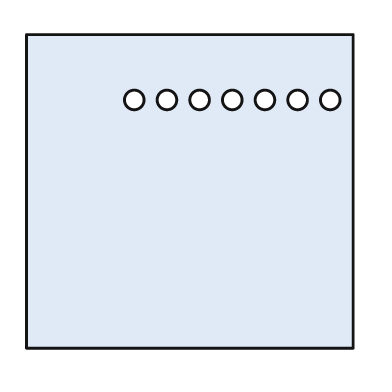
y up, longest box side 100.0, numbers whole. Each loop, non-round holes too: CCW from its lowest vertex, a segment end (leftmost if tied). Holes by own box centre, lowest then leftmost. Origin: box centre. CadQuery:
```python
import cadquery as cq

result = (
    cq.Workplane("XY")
    .moveTo(-50.0, -48.0)
    .lineTo(50.0, -48.0)
    .lineTo(50.0, 48.0)
    .lineTo(-50.0, 48.0)
    .close()
    .moveTo(-17.0, 28.0)
    .circle(3.0)
    .moveTo(-7.0, 28.0)
    .circle(3.0)
    .moveTo(3.0, 28.0)
    .circle(3.0)
    .moveTo(13.0, 28.0)
    .circle(3.0)
    .moveTo(23.0, 28.0)
    .circle(3.0)
    .moveTo(33.0, 28.0)
    .circle(3.0)
    .moveTo(43.0, 28.0)
    .circle(3.0)
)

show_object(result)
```